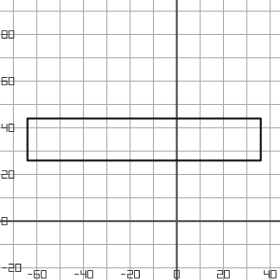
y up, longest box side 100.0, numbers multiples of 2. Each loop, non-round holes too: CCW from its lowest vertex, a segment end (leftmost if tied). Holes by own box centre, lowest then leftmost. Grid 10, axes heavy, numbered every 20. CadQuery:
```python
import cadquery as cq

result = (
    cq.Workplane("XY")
    .moveTo(-64.0, 26.0)
    .lineTo(36.0, 26.0)
    .lineTo(36.0, 44.0)
    .lineTo(-64.0, 44.0)
    .close()
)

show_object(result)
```